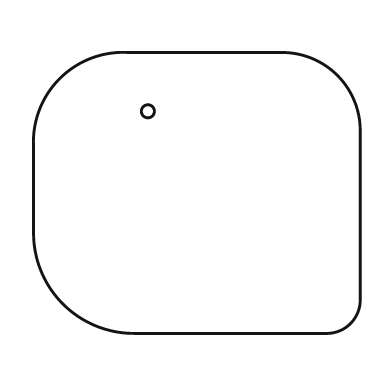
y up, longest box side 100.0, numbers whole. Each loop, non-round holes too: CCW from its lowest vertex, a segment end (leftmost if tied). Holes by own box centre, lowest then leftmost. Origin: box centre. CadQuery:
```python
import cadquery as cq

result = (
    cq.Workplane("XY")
    .moveTo(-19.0, -43.0)
    .lineTo(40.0, -43.0)
    .threePointArc((47.0, -40.0), (50.0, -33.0))
    .lineTo(50.0, 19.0)
    .threePointArc((43.0, 36.0), (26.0, 43.0))
    .lineTo(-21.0, 43.0)
    .threePointArc((-42.0, 35.0), (-50.0, 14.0))
    .lineTo(-50.0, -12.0)
    .threePointArc((-41.0, -34.0), (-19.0, -43.0))
    .close()
    .moveTo(-15.0, 25.0)
    .circle(2.0)
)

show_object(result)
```